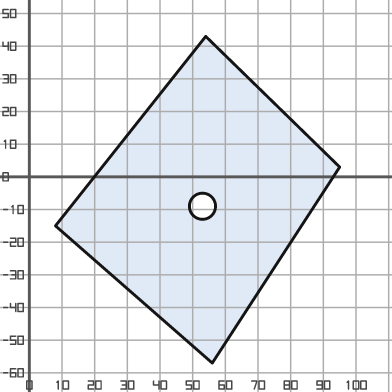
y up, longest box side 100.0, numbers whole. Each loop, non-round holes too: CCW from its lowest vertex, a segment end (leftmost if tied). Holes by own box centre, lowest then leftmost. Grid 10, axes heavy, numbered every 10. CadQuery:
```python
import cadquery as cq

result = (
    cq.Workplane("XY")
    .moveTo(56.0, -57.0)
    .lineTo(95.0, 3.0)
    .lineTo(54.0, 43.0)
    .lineTo(8.0, -15.0)
    .close()
    .moveTo(53.0, -9.0)
    .circle(4.0)
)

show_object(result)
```